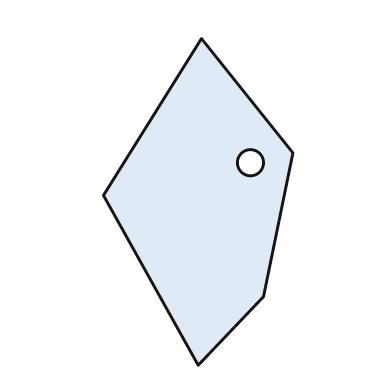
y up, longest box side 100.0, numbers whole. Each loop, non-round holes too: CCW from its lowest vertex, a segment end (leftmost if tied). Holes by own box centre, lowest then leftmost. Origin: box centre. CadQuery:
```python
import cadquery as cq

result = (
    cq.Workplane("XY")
    .moveTo(0.0, -50.0)
    .lineTo(20.0, -29.0)
    .lineTo(29.0, 15.0)
    .lineTo(1.0, 50.0)
    .lineTo(-29.0, 2.0)
    .close()
    .moveTo(16.0, 12.0)
    .circle(4.0)
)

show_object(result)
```